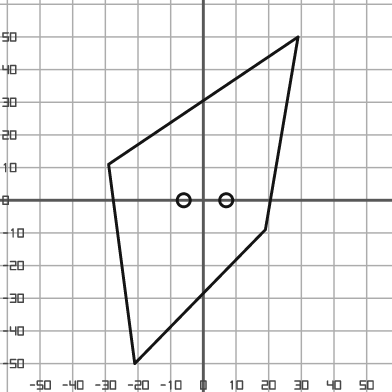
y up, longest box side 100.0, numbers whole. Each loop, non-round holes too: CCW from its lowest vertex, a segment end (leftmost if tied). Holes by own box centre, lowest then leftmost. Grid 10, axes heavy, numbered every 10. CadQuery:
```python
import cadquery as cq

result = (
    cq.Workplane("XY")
    .moveTo(-21.0, -50.0)
    .lineTo(19.0, -9.0)
    .lineTo(29.0, 50.0)
    .lineTo(-29.0, 11.0)
    .close()
    .moveTo(-6.0, 0.0)
    .circle(2.0)
    .moveTo(7.0, 0.0)
    .circle(2.0)
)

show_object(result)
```